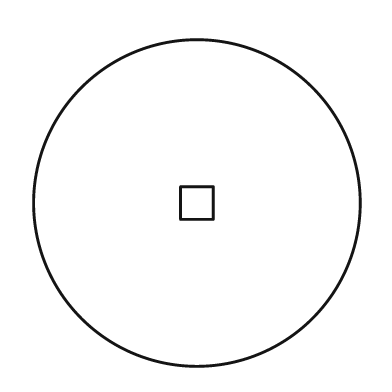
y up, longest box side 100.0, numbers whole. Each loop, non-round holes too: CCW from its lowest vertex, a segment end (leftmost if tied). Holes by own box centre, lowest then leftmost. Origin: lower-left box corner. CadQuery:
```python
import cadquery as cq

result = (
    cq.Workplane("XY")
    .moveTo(50.0, 50.0)
    .circle(50.0)
    .moveTo(45.0, 45.0)
    .lineTo(55.0, 45.0)
    .lineTo(55.0, 55.0)
    .lineTo(45.0, 55.0)
    .close()
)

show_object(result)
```